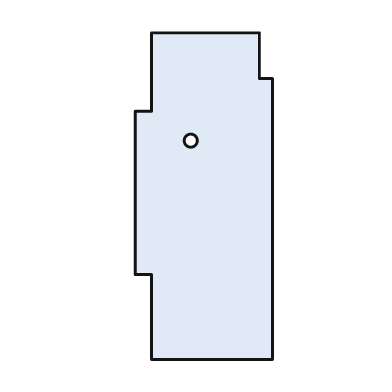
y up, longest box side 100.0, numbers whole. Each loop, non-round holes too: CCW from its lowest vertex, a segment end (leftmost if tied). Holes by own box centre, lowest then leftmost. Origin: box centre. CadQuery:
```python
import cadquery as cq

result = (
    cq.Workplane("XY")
    .moveTo(-16.0, -50.0)
    .lineTo(21.0, -50.0)
    .lineTo(21.0, 36.0)
    .lineTo(17.0, 36.0)
    .lineTo(17.0, 50.0)
    .lineTo(-16.0, 50.0)
    .lineTo(-16.0, 26.0)
    .lineTo(-21.0, 26.0)
    .lineTo(-21.0, -24.0)
    .lineTo(-16.0, -24.0)
    .close()
    .moveTo(-4.0, 17.0)
    .circle(2.0)
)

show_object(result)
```